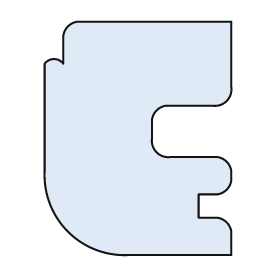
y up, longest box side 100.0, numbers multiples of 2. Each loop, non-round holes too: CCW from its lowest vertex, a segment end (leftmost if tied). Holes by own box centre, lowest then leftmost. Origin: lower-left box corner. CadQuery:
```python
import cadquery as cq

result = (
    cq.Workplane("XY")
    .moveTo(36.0, 0.0)
    .lineTo(80.0, 0.0)
    .lineTo(80.0, 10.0)
    .threePointArc((78.0, 14.0), (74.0, 16.0))
    .lineTo(66.0, 16.0)
    .lineTo(66.0, 26.0)
    .lineTo(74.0, 26.0)
    .threePointArc((78.0, 28.0), (80.0, 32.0))
    .lineTo(80.0, 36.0)
    .threePointArc((78.0, 40.0), (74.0, 42.0))
    .lineTo(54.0, 42.0)
    .threePointArc((48.0, 44.0), (46.0, 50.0))
    .lineTo(46.0, 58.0)
    .threePointArc((48.0, 62.0), (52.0, 64.0))
    .lineTo(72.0, 64.0)
    .threePointArc((78.0, 66.0), (80.0, 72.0))
    .lineTo(80.0, 100.0)
    .lineTo(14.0, 100.0)
    .threePointArc((10.0, 98.0), (8.0, 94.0))
    .lineTo(8.0, 82.0)
    .threePointArc((4.0, 84.0), (0.0, 82.0))
    .lineTo(0.0, 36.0)
    .threePointArc((10.0, 10.0), (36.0, 0.0))
    .close()
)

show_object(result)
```